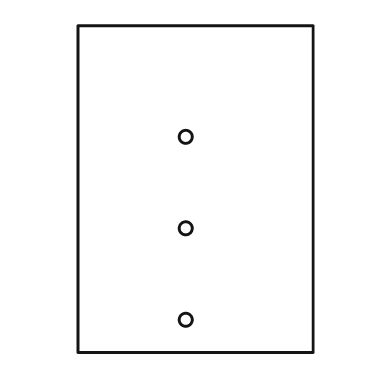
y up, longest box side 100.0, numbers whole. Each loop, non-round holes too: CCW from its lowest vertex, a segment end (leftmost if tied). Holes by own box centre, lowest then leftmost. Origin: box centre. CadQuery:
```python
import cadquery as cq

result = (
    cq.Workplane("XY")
    .moveTo(-36.0, -50.0)
    .lineTo(36.0, -50.0)
    .lineTo(36.0, 50.0)
    .lineTo(-36.0, 50.0)
    .close()
    .moveTo(-3.0, -40.0)
    .circle(2.0)
    .moveTo(-3.0, -12.0)
    .circle(2.0)
    .moveTo(-3.0, 16.0)
    .circle(2.0)
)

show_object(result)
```